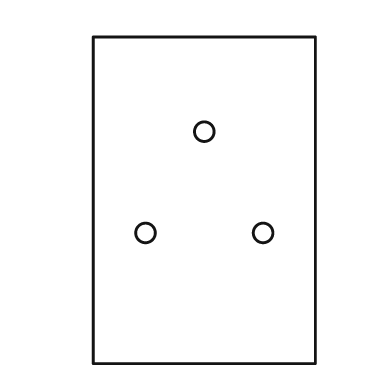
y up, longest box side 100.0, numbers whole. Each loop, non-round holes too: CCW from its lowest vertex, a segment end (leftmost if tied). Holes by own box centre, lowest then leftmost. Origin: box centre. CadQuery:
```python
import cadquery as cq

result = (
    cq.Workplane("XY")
    .moveTo(-34.0, -50.0)
    .lineTo(34.0, -50.0)
    .lineTo(34.0, 50.0)
    .lineTo(-34.0, 50.0)
    .close()
    .moveTo(-18.0, -10.0)
    .circle(3.0)
    .moveTo(18.0, -10.0)
    .circle(3.0)
    .moveTo(0.0, 21.0)
    .circle(3.0)
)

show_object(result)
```